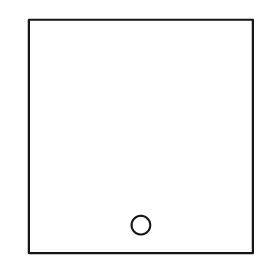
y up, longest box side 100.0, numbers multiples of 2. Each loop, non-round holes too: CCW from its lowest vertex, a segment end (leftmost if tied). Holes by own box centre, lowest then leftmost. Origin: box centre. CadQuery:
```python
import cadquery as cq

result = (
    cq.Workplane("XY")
    .moveTo(-48.0, -50.0)
    .lineTo(48.0, -50.0)
    .lineTo(48.0, 50.0)
    .lineTo(-48.0, 50.0)
    .close()
    .moveTo(0.0, -38.0)
    .circle(4.0)
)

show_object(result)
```